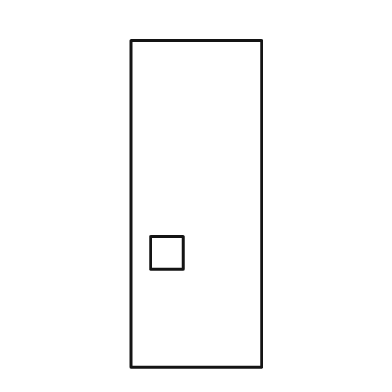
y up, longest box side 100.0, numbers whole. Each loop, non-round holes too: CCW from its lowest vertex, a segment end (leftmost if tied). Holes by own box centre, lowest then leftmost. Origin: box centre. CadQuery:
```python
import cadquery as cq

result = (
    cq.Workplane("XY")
    .moveTo(-20.0, -50.0)
    .lineTo(20.0, -50.0)
    .lineTo(20.0, 50.0)
    .lineTo(-20.0, 50.0)
    .close()
    .moveTo(-14.0, -20.0)
    .lineTo(-4.0, -20.0)
    .lineTo(-4.0, -10.0)
    .lineTo(-14.0, -10.0)
    .close()
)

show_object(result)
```